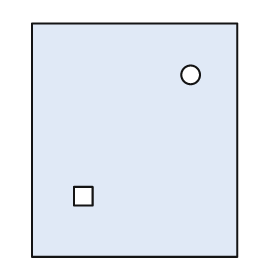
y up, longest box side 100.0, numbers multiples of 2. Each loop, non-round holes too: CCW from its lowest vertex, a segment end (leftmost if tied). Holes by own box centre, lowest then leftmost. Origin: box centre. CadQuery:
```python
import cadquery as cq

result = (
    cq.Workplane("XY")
    .moveTo(-44.0, -50.0)
    .lineTo(44.0, -50.0)
    .lineTo(44.0, 50.0)
    .lineTo(-44.0, 50.0)
    .close()
    .moveTo(-26.0, -28.0)
    .lineTo(-18.0, -28.0)
    .lineTo(-18.0, -20.0)
    .lineTo(-26.0, -20.0)
    .close()
    .moveTo(24.0, 28.0)
    .circle(4.0)
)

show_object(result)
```